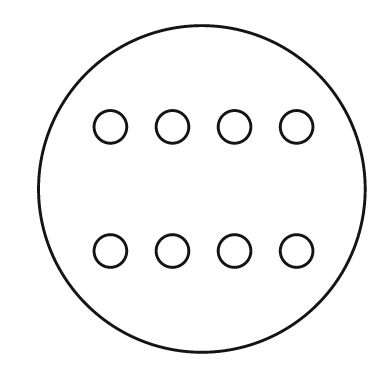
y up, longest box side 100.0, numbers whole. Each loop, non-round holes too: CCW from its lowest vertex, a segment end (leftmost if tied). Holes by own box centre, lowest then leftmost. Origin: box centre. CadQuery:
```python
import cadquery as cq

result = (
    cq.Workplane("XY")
    .moveTo(0.0, 0.0)
    .circle(50.0)
    .moveTo(-28.0, -19.0)
    .circle(5.0)
    .moveTo(-9.0, -19.0)
    .circle(5.0)
    .moveTo(10.0, -19.0)
    .circle(5.0)
    .moveTo(29.0, -19.0)
    .circle(5.0)
    .moveTo(-28.0, 19.0)
    .circle(5.0)
    .moveTo(-9.0, 19.0)
    .circle(5.0)
    .moveTo(10.0, 19.0)
    .circle(5.0)
    .moveTo(29.0, 19.0)
    .circle(5.0)
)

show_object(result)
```